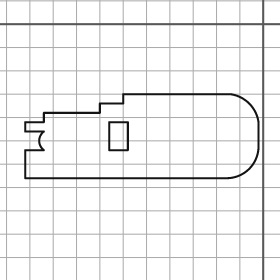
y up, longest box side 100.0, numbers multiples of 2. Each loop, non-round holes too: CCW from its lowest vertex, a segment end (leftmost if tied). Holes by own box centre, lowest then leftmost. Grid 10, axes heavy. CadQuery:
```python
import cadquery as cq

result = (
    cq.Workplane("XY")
    .moveTo(-102.0, -66.0)
    .lineTo(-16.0, -66.0)
    .threePointArc((-6.0, -62.0), (-2.0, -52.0))
    .lineTo(-2.0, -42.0)
    .threePointArc((-6.0, -34.0), (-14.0, -30.0))
    .lineTo(-60.0, -30.0)
    .lineTo(-60.0, -34.0)
    .lineTo(-70.0, -34.0)
    .lineTo(-70.0, -38.0)
    .lineTo(-94.0, -38.0)
    .lineTo(-94.0, -42.0)
    .lineTo(-102.0, -42.0)
    .lineTo(-102.0, -46.0)
    .lineTo(-94.0, -46.0)
    .threePointArc((-96.0, -50.0), (-94.0, -54.0))
    .lineTo(-102.0, -54.0)
    .close()
    .moveTo(-66.0, -54.0)
    .lineTo(-58.0, -54.0)
    .lineTo(-58.0, -42.0)
    .lineTo(-66.0, -42.0)
    .close()
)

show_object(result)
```